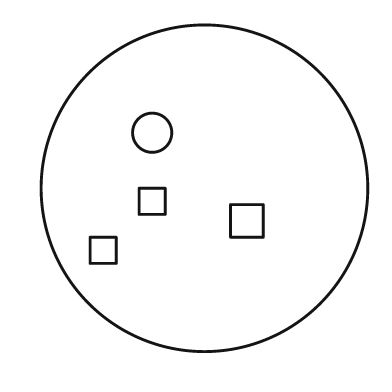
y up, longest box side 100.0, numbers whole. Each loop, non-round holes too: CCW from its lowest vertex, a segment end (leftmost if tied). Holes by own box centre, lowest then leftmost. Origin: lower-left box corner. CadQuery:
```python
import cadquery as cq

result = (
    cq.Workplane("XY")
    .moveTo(50.0, 50.0)
    .circle(50.0)
    .moveTo(15.0, 27.0)
    .lineTo(23.0, 27.0)
    .lineTo(23.0, 35.0)
    .lineTo(15.0, 35.0)
    .close()
    .moveTo(58.0, 35.0)
    .lineTo(68.0, 35.0)
    .lineTo(68.0, 45.0)
    .lineTo(58.0, 45.0)
    .close()
    .moveTo(30.0, 42.0)
    .lineTo(38.0, 42.0)
    .lineTo(38.0, 50.0)
    .lineTo(30.0, 50.0)
    .close()
    .moveTo(34.0, 67.0)
    .circle(6.0)
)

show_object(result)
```